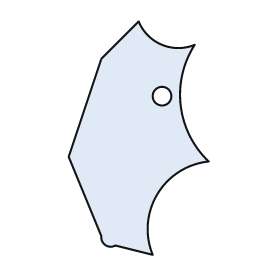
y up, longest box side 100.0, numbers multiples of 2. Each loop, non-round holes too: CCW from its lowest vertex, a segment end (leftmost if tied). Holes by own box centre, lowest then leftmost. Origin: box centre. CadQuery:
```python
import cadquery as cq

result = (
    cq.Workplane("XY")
    .moveTo(6.0, -50.0)
    .threePointArc((8.0, -24.0), (30.0, -10.0))
    .threePointArc((18.0, 14.0), (24.0, 40.0))
    .threePointArc((10.0, 40.0), (0.0, 50.0))
    .lineTo(-16.0, 34.0)
    .lineTo(-30.0, -8.0)
    .lineTo(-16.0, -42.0)
    .threePointArc((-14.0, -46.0), (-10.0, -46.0))
    .close()
    .moveTo(10.0, 18.0)
    .circle(4.0)
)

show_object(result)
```